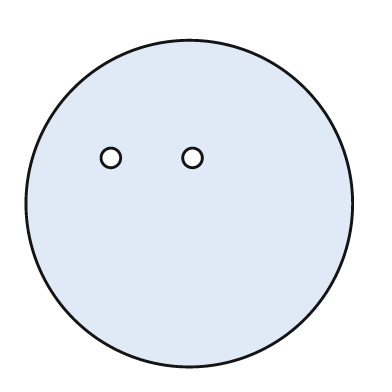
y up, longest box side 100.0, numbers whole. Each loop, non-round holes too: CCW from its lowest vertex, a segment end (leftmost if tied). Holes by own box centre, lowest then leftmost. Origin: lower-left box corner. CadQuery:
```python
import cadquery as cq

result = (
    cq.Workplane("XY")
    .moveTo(50.0, 50.0)
    .circle(50.0)
    .moveTo(26.0, 64.0)
    .circle(3.0)
    .moveTo(51.0, 64.0)
    .circle(3.0)
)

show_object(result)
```